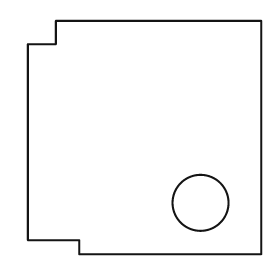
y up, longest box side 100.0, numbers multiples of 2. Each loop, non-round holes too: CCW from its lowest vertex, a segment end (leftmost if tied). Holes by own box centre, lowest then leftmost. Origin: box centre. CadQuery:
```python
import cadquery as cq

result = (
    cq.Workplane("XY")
    .moveTo(-28.0, -50.0)
    .lineTo(50.0, -50.0)
    .lineTo(50.0, 50.0)
    .lineTo(-38.0, 50.0)
    .lineTo(-38.0, 40.0)
    .lineTo(-50.0, 40.0)
    .lineTo(-50.0, -44.0)
    .lineTo(-28.0, -44.0)
    .close()
    .moveTo(24.0, -28.0)
    .circle(12.0)
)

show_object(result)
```